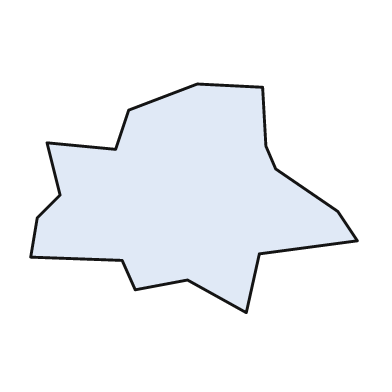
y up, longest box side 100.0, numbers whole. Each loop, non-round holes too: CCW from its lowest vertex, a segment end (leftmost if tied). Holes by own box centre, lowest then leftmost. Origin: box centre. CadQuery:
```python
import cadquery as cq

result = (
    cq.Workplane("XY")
    .moveTo(16.0, -35.0)
    .lineTo(20.0, -17.0)
    .lineTo(50.0, -13.0)
    .lineTo(44.0, -4.0)
    .lineTo(25.0, 9.0)
    .lineTo(22.0, 16.0)
    .lineTo(21.0, 34.0)
    .lineTo(1.0, 35.0)
    .lineTo(-20.0, 27.0)
    .lineTo(-24.0, 15.0)
    .lineTo(-45.0, 17.0)
    .lineTo(-41.0, 1.0)
    .lineTo(-48.0, -6.0)
    .lineTo(-50.0, -18.0)
    .lineTo(-22.0, -19.0)
    .lineTo(-18.0, -28.0)
    .lineTo(-2.0, -25.0)
    .close()
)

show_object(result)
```